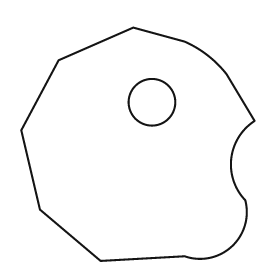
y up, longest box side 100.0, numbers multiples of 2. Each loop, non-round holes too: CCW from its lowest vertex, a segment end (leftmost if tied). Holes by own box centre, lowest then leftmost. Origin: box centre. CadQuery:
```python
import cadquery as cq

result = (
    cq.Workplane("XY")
    .moveTo(-16.0, -50.0)
    .lineTo(20.0, -48.0)
    .threePointArc((40.0, -44.0), (46.0, -24.0))
    .threePointArc((40.0, -6.0), (50.0, 10.0))
    .lineTo(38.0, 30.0)
    .threePointArc((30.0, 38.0), (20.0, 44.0))
    .lineTo(-2.0, 50.0)
    .lineTo(-34.0, 36.0)
    .lineTo(-50.0, 6.0)
    .lineTo(-42.0, -28.0)
    .close()
    .moveTo(6.0, 18.0)
    .circle(10.0)
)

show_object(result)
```